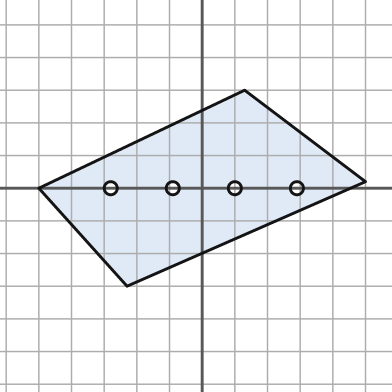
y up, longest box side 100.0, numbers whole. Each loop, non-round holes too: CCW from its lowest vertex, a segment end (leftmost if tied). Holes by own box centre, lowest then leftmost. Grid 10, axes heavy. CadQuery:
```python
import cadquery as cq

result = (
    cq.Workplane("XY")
    .moveTo(-23.0, -30.0)
    .lineTo(50.0, 2.0)
    .lineTo(13.0, 30.0)
    .lineTo(-50.0, 0.0)
    .close()
    .moveTo(-28.0, 0.0)
    .circle(2.0)
    .moveTo(-9.0, 0.0)
    .circle(2.0)
    .moveTo(10.0, 0.0)
    .circle(2.0)
    .moveTo(29.0, 0.0)
    .circle(2.0)
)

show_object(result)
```